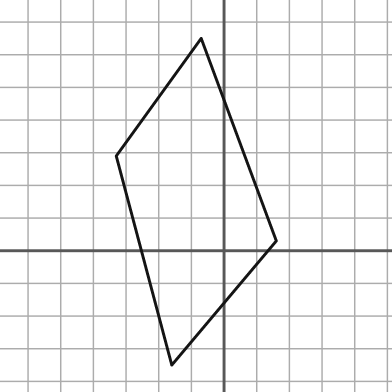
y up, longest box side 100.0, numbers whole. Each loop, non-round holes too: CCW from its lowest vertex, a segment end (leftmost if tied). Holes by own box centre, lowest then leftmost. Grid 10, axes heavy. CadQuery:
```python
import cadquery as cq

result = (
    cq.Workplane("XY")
    .moveTo(-16.0, -35.0)
    .lineTo(16.0, 3.0)
    .lineTo(-7.0, 65.0)
    .lineTo(-33.0, 29.0)
    .close()
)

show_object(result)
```